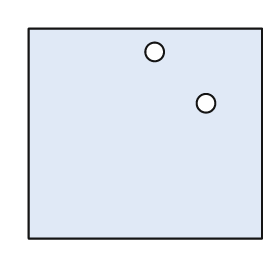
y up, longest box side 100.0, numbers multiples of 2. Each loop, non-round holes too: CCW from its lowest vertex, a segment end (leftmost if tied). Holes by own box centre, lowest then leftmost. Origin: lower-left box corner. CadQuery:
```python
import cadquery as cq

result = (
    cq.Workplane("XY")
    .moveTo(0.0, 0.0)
    .lineTo(100.0, 0.0)
    .lineTo(100.0, 90.0)
    .lineTo(0.0, 90.0)
    .close()
    .moveTo(76.0, 58.0)
    .circle(4.0)
    .moveTo(54.0, 80.0)
    .circle(4.0)
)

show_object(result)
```